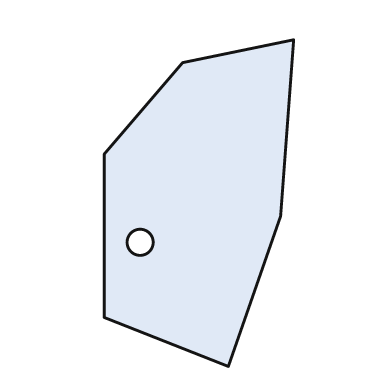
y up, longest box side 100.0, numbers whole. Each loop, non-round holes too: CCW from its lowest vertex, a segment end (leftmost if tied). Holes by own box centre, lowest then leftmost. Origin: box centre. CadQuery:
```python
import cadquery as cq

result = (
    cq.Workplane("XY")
    .moveTo(9.0, -50.0)
    .lineTo(25.0, -4.0)
    .lineTo(29.0, 50.0)
    .lineTo(-5.0, 43.0)
    .lineTo(-29.0, 15.0)
    .lineTo(-29.0, -35.0)
    .close()
    .moveTo(-18.0, -12.0)
    .circle(4.0)
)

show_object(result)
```